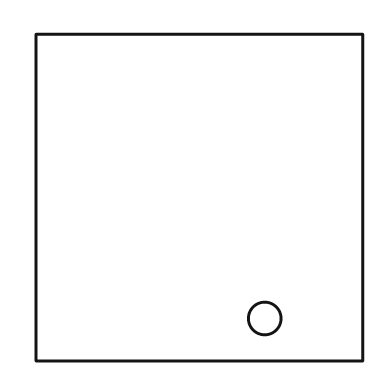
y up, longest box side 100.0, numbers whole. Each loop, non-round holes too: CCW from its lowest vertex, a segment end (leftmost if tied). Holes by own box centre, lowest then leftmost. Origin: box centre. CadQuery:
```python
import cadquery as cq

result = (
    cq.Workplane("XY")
    .moveTo(-50.0, -50.0)
    .lineTo(50.0, -50.0)
    .lineTo(50.0, 50.0)
    .lineTo(-50.0, 50.0)
    .close()
    .moveTo(20.0, -37.0)
    .circle(5.0)
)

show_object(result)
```